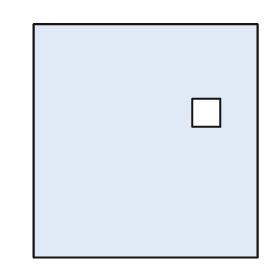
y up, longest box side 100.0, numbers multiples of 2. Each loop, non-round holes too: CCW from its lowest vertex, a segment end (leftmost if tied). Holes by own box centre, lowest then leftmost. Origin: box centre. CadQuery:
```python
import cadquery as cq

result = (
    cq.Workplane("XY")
    .moveTo(-48.0, -50.0)
    .lineTo(48.0, -50.0)
    .lineTo(48.0, 50.0)
    .lineTo(-48.0, 50.0)
    .close()
    .moveTo(20.0, 6.0)
    .lineTo(32.0, 6.0)
    .lineTo(32.0, 18.0)
    .lineTo(20.0, 18.0)
    .close()
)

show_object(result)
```